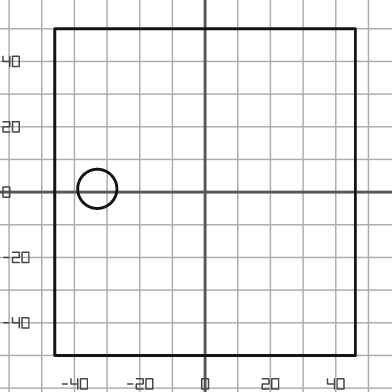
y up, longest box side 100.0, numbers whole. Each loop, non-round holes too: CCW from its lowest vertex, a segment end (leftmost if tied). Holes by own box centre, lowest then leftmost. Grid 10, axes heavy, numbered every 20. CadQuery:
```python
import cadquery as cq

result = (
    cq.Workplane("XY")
    .moveTo(-46.0, -50.0)
    .lineTo(46.0, -50.0)
    .lineTo(46.0, 50.0)
    .lineTo(-46.0, 50.0)
    .close()
    .moveTo(-33.0, 1.0)
    .circle(6.0)
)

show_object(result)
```